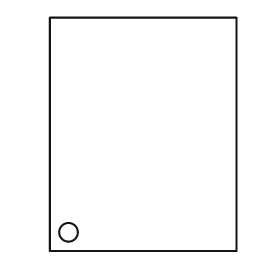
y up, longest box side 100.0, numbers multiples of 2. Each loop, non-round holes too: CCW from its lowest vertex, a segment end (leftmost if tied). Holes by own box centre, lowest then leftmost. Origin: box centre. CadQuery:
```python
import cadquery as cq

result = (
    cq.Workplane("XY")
    .moveTo(-40.0, -50.0)
    .lineTo(40.0, -50.0)
    .lineTo(40.0, 50.0)
    .lineTo(-40.0, 50.0)
    .close()
    .moveTo(-32.0, -42.0)
    .circle(4.0)
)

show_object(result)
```